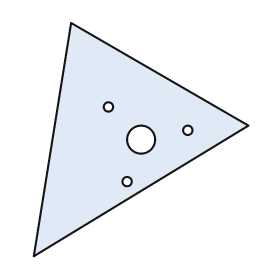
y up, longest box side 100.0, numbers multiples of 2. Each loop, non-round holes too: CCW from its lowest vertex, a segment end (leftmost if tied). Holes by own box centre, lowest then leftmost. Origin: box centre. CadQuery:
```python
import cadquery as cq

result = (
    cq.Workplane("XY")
    .moveTo(-46.0, -50.0)
    .lineTo(46.0, 6.0)
    .lineTo(-30.0, 50.0)
    .close()
    .moveTo(-6.0, -18.0)
    .circle(2.0)
    .moveTo(0.0, 0.0)
    .circle(6.0)
    .moveTo(20.0, 4.0)
    .circle(2.0)
    .moveTo(-14.0, 14.0)
    .circle(2.0)
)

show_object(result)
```